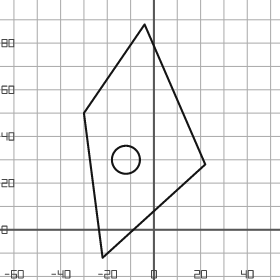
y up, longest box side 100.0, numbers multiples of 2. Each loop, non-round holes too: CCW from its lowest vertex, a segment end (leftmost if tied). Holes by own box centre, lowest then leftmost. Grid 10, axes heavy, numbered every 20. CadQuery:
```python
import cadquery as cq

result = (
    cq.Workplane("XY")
    .moveTo(-22.0, -12.0)
    .lineTo(22.0, 28.0)
    .lineTo(-4.0, 88.0)
    .lineTo(-30.0, 50.0)
    .close()
    .moveTo(-12.0, 30.0)
    .circle(6.0)
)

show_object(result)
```